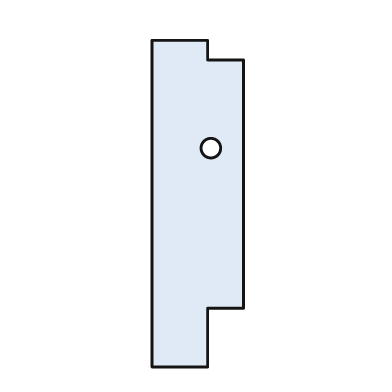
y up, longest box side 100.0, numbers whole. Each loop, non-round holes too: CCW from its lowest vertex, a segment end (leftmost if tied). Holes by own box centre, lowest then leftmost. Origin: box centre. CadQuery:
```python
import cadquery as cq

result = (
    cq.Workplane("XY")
    .moveTo(-14.0, -50.0)
    .lineTo(3.0, -50.0)
    .lineTo(3.0, -32.0)
    .lineTo(14.0, -32.0)
    .lineTo(14.0, 44.0)
    .lineTo(3.0, 44.0)
    .lineTo(3.0, 50.0)
    .lineTo(-14.0, 50.0)
    .close()
    .moveTo(4.0, 17.0)
    .circle(3.0)
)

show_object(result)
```